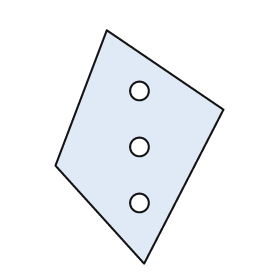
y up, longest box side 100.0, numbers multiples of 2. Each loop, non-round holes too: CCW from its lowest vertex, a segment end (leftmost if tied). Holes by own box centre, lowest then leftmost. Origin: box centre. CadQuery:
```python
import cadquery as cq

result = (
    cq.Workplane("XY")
    .moveTo(2.0, -50.0)
    .lineTo(36.0, 16.0)
    .lineTo(-14.0, 50.0)
    .lineTo(-36.0, -8.0)
    .close()
    .moveTo(0.0, -24.0)
    .circle(4.0)
    .moveTo(0.0, 0.0)
    .circle(4.0)
    .moveTo(0.0, 24.0)
    .circle(4.0)
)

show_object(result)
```